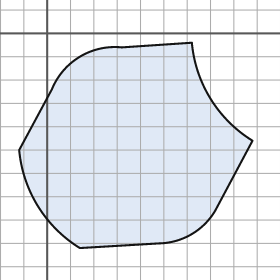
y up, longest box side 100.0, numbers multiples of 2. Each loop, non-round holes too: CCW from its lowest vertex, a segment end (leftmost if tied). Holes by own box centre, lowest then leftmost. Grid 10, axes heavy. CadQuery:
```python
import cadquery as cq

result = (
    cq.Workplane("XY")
    .moveTo(14.0, -92.0)
    .lineTo(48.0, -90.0)
    .threePointArc((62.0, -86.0), (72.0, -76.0))
    .lineTo(88.0, -46.0)
    .threePointArc((70.0, -28.0), (62.0, -4.0))
    .lineTo(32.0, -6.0)
    .threePointArc((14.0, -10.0), (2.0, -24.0))
    .lineTo(-12.0, -50.0)
    .threePointArc((-4.0, -74.0), (14.0, -92.0))
    .close()
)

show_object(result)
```